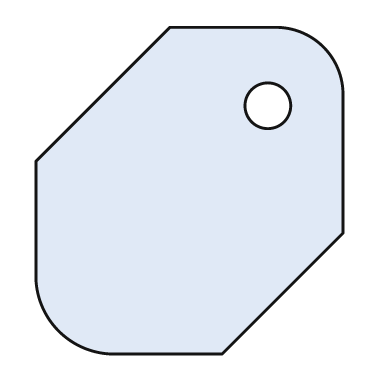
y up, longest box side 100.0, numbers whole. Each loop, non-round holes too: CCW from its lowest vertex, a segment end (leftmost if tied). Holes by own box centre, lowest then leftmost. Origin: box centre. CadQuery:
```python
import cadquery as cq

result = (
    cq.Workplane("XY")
    .moveTo(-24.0, -50.0)
    .lineTo(10.0, -50.0)
    .lineTo(47.0, -13.0)
    .lineTo(47.0, 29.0)
    .threePointArc((41.0, 44.0), (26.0, 50.0))
    .lineTo(-6.0, 50.0)
    .lineTo(-47.0, 9.0)
    .lineTo(-47.0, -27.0)
    .threePointArc((-40.0, -43.0), (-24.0, -50.0))
    .close()
    .moveTo(24.0, 26.0)
    .circle(7.0)
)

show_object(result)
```